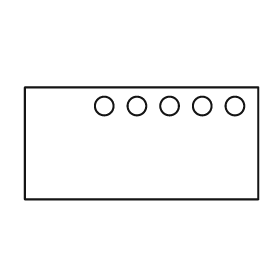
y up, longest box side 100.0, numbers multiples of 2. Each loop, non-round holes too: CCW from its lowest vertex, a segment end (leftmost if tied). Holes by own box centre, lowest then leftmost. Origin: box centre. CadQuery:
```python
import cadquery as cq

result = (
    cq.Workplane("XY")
    .moveTo(-50.0, -24.0)
    .lineTo(50.0, -24.0)
    .lineTo(50.0, 24.0)
    .lineTo(-50.0, 24.0)
    .close()
    .moveTo(-16.0, 16.0)
    .circle(4.0)
    .moveTo(-2.0, 16.0)
    .circle(4.0)
    .moveTo(12.0, 16.0)
    .circle(4.0)
    .moveTo(26.0, 16.0)
    .circle(4.0)
    .moveTo(40.0, 16.0)
    .circle(4.0)
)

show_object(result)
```